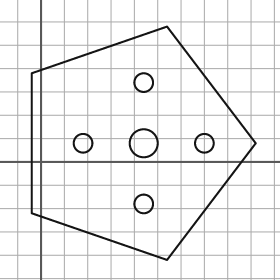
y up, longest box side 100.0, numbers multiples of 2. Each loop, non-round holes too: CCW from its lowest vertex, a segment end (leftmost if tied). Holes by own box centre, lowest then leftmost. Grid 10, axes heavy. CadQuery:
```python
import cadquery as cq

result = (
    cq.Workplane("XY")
    .moveTo(54.0, -42.0)
    .lineTo(92.0, 8.0)
    .lineTo(54.0, 58.0)
    .lineTo(-4.0, 38.0)
    .lineTo(-4.0, -22.0)
    .close()
    .moveTo(44.0, -18.0)
    .circle(4.0)
    .moveTo(18.0, 8.0)
    .circle(4.0)
    .moveTo(44.0, 8.0)
    .circle(6.0)
    .moveTo(70.0, 8.0)
    .circle(4.0)
    .moveTo(44.0, 34.0)
    .circle(4.0)
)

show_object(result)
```